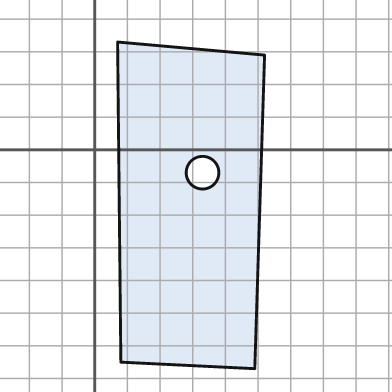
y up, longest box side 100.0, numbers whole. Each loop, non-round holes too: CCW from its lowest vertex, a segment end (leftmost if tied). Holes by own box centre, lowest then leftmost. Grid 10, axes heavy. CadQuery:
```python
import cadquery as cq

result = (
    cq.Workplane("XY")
    .moveTo(49.0, -67.0)
    .lineTo(52.0, 29.0)
    .lineTo(7.0, 33.0)
    .lineTo(8.0, -65.0)
    .close()
    .moveTo(33.0, -7.0)
    .circle(5.0)
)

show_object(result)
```